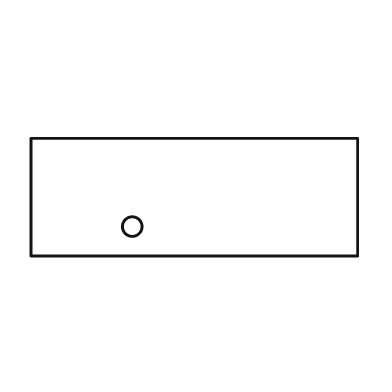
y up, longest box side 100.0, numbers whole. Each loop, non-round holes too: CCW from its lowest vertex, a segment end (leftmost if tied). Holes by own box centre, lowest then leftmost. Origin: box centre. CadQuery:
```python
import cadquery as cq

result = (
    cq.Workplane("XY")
    .moveTo(-50.0, -18.0)
    .lineTo(50.0, -18.0)
    .lineTo(50.0, 18.0)
    .lineTo(-50.0, 18.0)
    .close()
    .moveTo(-19.0, -9.0)
    .circle(3.0)
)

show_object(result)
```